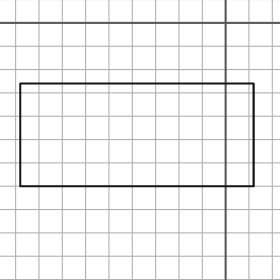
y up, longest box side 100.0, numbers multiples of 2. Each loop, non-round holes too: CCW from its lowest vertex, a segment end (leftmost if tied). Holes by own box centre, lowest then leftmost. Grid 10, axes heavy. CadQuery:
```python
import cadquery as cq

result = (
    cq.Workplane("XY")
    .moveTo(-88.0, -70.0)
    .lineTo(12.0, -70.0)
    .lineTo(12.0, -26.0)
    .lineTo(-88.0, -26.0)
    .close()
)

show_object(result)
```